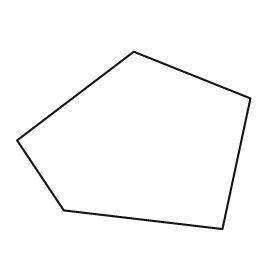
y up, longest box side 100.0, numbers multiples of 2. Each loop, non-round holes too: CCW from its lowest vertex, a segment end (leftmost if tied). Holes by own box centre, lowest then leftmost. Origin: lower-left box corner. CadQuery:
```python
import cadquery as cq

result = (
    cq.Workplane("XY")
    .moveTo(88.0, 0.0)
    .lineTo(100.0, 56.0)
    .lineTo(50.0, 76.0)
    .lineTo(0.0, 38.0)
    .lineTo(20.0, 8.0)
    .close()
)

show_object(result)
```